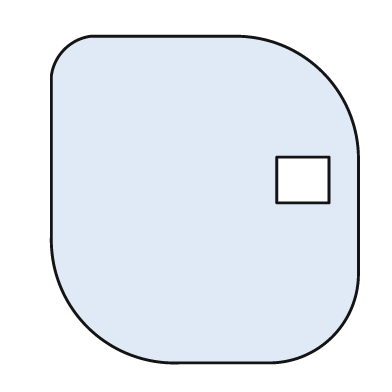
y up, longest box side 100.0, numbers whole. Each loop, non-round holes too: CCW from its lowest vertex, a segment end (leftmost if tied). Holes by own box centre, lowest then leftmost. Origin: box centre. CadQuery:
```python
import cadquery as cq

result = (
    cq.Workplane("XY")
    .moveTo(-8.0, -50.0)
    .lineTo(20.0, -50.0)
    .threePointArc((39.0, -42.0), (47.0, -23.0))
    .lineTo(47.0, 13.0)
    .threePointArc((36.0, 39.0), (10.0, 50.0))
    .lineTo(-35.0, 50.0)
    .threePointArc((-43.0, 46.0), (-47.0, 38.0))
    .lineTo(-47.0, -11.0)
    .threePointArc((-36.0, -39.0), (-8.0, -50.0))
    .close()
    .moveTo(22.0, -1.0)
    .lineTo(38.0, -1.0)
    .lineTo(38.0, 13.0)
    .lineTo(22.0, 13.0)
    .close()
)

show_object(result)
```